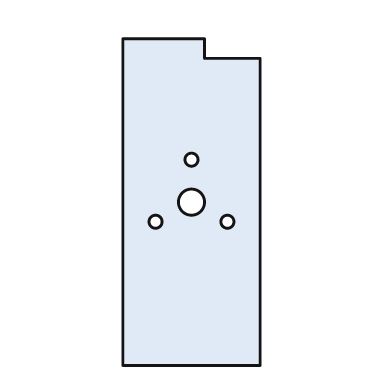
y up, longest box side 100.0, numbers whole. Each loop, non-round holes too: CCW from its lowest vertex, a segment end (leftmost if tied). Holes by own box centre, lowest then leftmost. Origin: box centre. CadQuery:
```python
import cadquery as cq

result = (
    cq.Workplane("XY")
    .moveTo(-21.0, -50.0)
    .lineTo(21.0, -50.0)
    .lineTo(21.0, 44.0)
    .lineTo(4.0, 44.0)
    .lineTo(4.0, 50.0)
    .lineTo(-21.0, 50.0)
    .close()
    .moveTo(-11.0, -6.0)
    .circle(2.0)
    .moveTo(11.0, -6.0)
    .circle(2.0)
    .moveTo(0.0, 0.0)
    .circle(4.0)
    .moveTo(0.0, 13.0)
    .circle(2.0)
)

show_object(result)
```